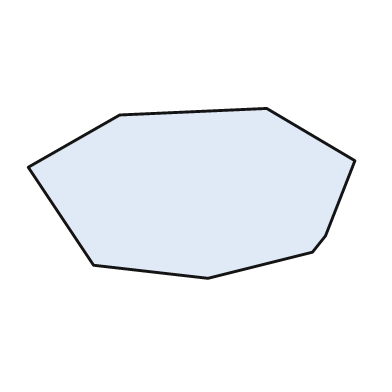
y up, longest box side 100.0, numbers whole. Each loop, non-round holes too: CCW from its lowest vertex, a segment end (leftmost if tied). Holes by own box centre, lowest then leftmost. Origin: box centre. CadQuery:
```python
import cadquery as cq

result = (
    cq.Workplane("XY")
    .moveTo(5.0, -26.0)
    .lineTo(37.0, -18.0)
    .lineTo(41.0, -13.0)
    .lineTo(50.0, 10.0)
    .lineTo(23.0, 26.0)
    .lineTo(-22.0, 24.0)
    .lineTo(-50.0, 8.0)
    .lineTo(-30.0, -22.0)
    .close()
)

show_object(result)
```